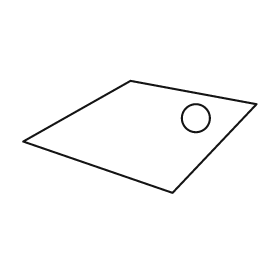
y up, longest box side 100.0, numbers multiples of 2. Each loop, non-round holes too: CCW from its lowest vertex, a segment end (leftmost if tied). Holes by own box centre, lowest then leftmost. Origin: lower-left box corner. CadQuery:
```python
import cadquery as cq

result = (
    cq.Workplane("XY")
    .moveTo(64.0, 0.0)
    .lineTo(100.0, 38.0)
    .lineTo(46.0, 48.0)
    .lineTo(0.0, 22.0)
    .close()
    .moveTo(74.0, 32.0)
    .circle(6.0)
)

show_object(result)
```